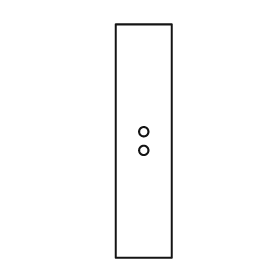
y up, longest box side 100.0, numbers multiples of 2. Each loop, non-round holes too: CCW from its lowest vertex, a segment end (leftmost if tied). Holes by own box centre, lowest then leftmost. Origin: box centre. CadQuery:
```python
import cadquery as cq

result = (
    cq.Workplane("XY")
    .moveTo(-12.0, -50.0)
    .lineTo(12.0, -50.0)
    .lineTo(12.0, 50.0)
    .lineTo(-12.0, 50.0)
    .close()
    .moveTo(0.0, -4.0)
    .circle(2.0)
    .moveTo(0.0, 4.0)
    .circle(2.0)
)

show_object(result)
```